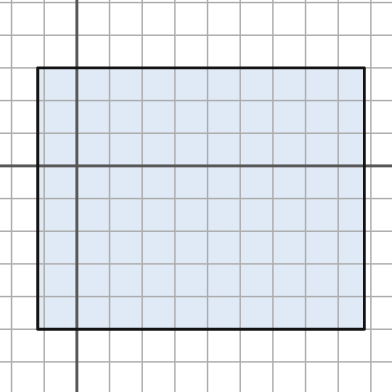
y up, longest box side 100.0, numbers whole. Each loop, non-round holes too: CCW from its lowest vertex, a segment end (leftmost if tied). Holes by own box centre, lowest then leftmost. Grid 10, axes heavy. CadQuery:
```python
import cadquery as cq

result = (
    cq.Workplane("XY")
    .moveTo(-12.0, -50.0)
    .lineTo(88.0, -50.0)
    .lineTo(88.0, 30.0)
    .lineTo(-12.0, 30.0)
    .close()
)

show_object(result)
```